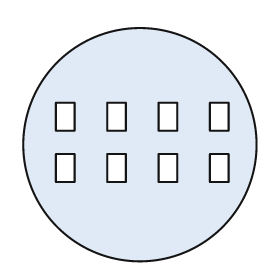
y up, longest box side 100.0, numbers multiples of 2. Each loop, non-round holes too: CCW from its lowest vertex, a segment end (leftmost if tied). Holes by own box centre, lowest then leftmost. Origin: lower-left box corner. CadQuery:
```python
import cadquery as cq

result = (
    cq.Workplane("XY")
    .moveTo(50.0, 50.0)
    .circle(50.0)
    .moveTo(14.0, 34.0)
    .lineTo(22.0, 34.0)
    .lineTo(22.0, 46.0)
    .lineTo(14.0, 46.0)
    .close()
    .moveTo(36.0, 34.0)
    .lineTo(44.0, 34.0)
    .lineTo(44.0, 46.0)
    .lineTo(36.0, 46.0)
    .close()
    .moveTo(58.0, 34.0)
    .lineTo(66.0, 34.0)
    .lineTo(66.0, 46.0)
    .lineTo(58.0, 46.0)
    .close()
    .moveTo(80.0, 34.0)
    .lineTo(88.0, 34.0)
    .lineTo(88.0, 46.0)
    .lineTo(80.0, 46.0)
    .close()
    .moveTo(14.0, 56.0)
    .lineTo(22.0, 56.0)
    .lineTo(22.0, 68.0)
    .lineTo(14.0, 68.0)
    .close()
    .moveTo(36.0, 56.0)
    .lineTo(44.0, 56.0)
    .lineTo(44.0, 68.0)
    .lineTo(36.0, 68.0)
    .close()
    .moveTo(58.0, 56.0)
    .lineTo(66.0, 56.0)
    .lineTo(66.0, 68.0)
    .lineTo(58.0, 68.0)
    .close()
    .moveTo(80.0, 56.0)
    .lineTo(88.0, 56.0)
    .lineTo(88.0, 68.0)
    .lineTo(80.0, 68.0)
    .close()
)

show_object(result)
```